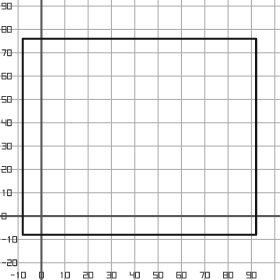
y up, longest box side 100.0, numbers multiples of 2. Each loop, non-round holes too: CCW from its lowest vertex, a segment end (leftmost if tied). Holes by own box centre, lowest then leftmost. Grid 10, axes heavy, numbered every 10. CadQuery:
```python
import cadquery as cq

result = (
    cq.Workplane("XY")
    .moveTo(-8.0, -8.0)
    .lineTo(92.0, -8.0)
    .lineTo(92.0, 76.0)
    .lineTo(-8.0, 76.0)
    .close()
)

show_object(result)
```